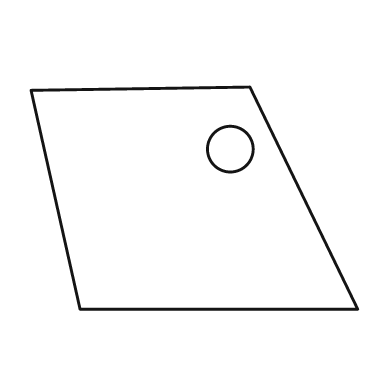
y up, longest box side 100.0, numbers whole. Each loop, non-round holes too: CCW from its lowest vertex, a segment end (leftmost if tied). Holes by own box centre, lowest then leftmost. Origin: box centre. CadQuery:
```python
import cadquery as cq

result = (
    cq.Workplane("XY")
    .moveTo(-35.0, -34.0)
    .lineTo(50.0, -34.0)
    .lineTo(17.0, 34.0)
    .lineTo(-50.0, 33.0)
    .close()
    .moveTo(11.0, 15.0)
    .circle(7.0)
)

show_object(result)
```